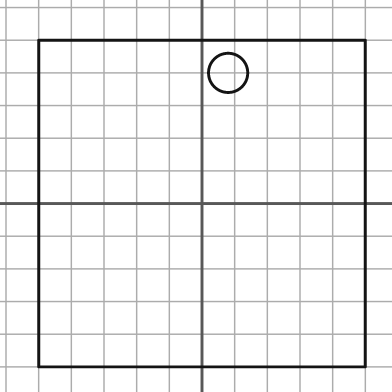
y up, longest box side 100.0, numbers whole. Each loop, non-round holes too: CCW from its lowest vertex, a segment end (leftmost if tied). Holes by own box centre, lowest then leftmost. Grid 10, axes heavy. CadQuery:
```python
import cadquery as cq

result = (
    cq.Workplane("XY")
    .moveTo(-50.0, -50.0)
    .lineTo(50.0, -50.0)
    .lineTo(50.0, 50.0)
    .lineTo(-50.0, 50.0)
    .close()
    .moveTo(8.0, 40.0)
    .circle(6.0)
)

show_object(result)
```